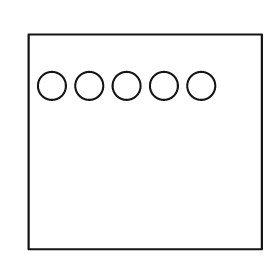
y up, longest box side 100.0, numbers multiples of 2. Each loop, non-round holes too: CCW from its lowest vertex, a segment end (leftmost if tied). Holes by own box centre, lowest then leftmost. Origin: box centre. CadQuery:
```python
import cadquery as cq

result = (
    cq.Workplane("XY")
    .moveTo(-50.0, -46.0)
    .lineTo(50.0, -46.0)
    .lineTo(50.0, 46.0)
    .lineTo(-50.0, 46.0)
    .close()
    .moveTo(-40.0, 24.0)
    .circle(6.0)
    .moveTo(-24.0, 24.0)
    .circle(6.0)
    .moveTo(-8.0, 24.0)
    .circle(6.0)
    .moveTo(8.0, 24.0)
    .circle(6.0)
    .moveTo(24.0, 24.0)
    .circle(6.0)
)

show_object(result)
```